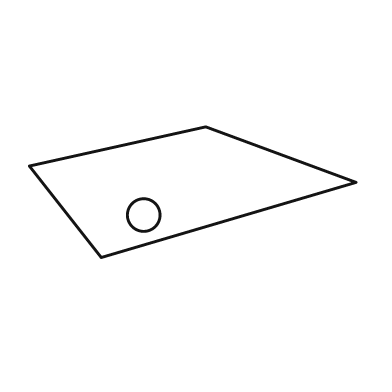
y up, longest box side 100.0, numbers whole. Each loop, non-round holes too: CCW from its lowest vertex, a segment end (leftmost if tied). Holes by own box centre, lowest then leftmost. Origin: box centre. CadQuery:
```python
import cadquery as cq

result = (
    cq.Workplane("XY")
    .moveTo(-28.0, -20.0)
    .lineTo(50.0, 3.0)
    .lineTo(4.0, 20.0)
    .lineTo(-50.0, 8.0)
    .close()
    .moveTo(-15.0, -7.0)
    .circle(5.0)
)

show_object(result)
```